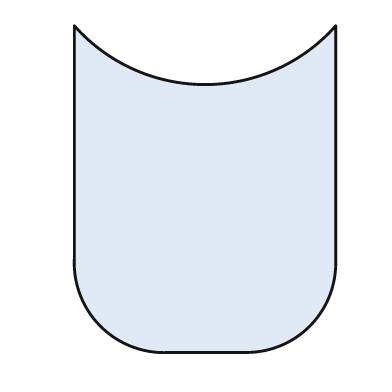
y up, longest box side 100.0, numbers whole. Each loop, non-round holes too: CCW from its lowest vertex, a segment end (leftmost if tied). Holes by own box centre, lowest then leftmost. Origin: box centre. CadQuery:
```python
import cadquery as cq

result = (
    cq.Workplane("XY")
    .moveTo(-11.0, -50.0)
    .lineTo(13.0, -50.0)
    .threePointArc((32.0, -42.0), (40.0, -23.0))
    .lineTo(40.0, 50.0)
    .threePointArc((0.0, 32.0), (-40.0, 50.0))
    .lineTo(-40.0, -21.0)
    .threePointArc((-32.0, -42.0), (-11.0, -50.0))
    .close()
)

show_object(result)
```